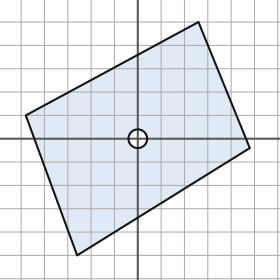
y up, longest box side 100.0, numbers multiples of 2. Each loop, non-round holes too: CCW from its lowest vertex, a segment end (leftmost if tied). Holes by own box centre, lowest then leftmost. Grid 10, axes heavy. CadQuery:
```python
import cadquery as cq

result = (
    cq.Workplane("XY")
    .moveTo(-26.0, -50.0)
    .lineTo(48.0, -4.0)
    .lineTo(26.0, 50.0)
    .lineTo(-48.0, 10.0)
    .close()
    .moveTo(0.0, 0.0)
    .circle(4.0)
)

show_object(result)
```